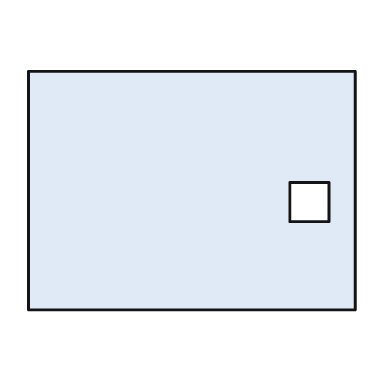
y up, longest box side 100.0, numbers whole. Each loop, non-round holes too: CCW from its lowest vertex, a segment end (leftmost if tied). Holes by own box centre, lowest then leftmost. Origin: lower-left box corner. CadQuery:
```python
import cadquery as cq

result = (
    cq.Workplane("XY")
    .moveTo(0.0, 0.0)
    .lineTo(100.0, 0.0)
    .lineTo(100.0, 73.0)
    .lineTo(0.0, 73.0)
    .close()
    .moveTo(80.0, 27.0)
    .lineTo(92.0, 27.0)
    .lineTo(92.0, 39.0)
    .lineTo(80.0, 39.0)
    .close()
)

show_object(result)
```